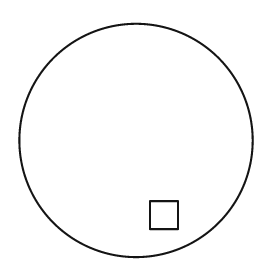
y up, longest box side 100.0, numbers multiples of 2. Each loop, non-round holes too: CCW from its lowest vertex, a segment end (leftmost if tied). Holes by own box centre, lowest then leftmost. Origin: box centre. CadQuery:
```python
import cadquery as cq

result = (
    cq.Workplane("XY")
    .moveTo(0.0, 0.0)
    .circle(50.0)
    .moveTo(6.0, -38.0)
    .lineTo(18.0, -38.0)
    .lineTo(18.0, -26.0)
    .lineTo(6.0, -26.0)
    .close()
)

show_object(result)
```